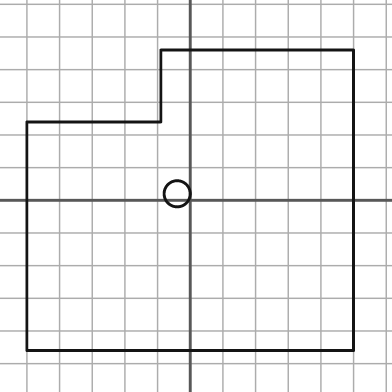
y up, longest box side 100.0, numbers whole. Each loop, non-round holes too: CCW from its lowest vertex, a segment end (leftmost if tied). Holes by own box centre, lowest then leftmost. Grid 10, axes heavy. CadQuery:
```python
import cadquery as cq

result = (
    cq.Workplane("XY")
    .moveTo(-50.0, -46.0)
    .lineTo(50.0, -46.0)
    .lineTo(50.0, 46.0)
    .lineTo(-9.0, 46.0)
    .lineTo(-9.0, 24.0)
    .lineTo(-50.0, 24.0)
    .close()
    .moveTo(-4.0, 2.0)
    .circle(4.0)
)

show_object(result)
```